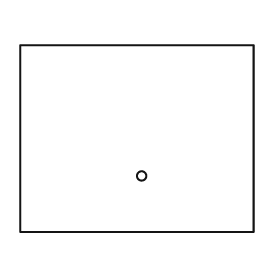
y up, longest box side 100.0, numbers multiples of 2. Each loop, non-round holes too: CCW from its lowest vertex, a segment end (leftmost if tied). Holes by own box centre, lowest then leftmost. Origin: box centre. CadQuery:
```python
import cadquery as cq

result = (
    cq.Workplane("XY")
    .moveTo(-50.0, -40.0)
    .lineTo(50.0, -40.0)
    .lineTo(50.0, 40.0)
    .lineTo(-50.0, 40.0)
    .close()
    .moveTo(2.0, -16.0)
    .circle(2.0)
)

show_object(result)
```